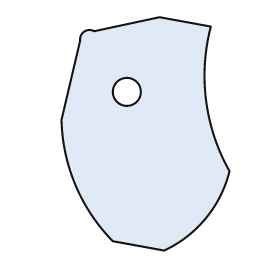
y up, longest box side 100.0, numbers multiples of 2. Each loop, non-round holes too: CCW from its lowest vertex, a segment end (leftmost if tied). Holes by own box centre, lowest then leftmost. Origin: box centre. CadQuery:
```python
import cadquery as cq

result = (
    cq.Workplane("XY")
    .moveTo(8.0, -50.0)
    .threePointArc((26.0, -36.0), (36.0, -16.0))
    .threePointArc((26.0, 14.0), (28.0, 46.0))
    .lineTo(6.0, 50.0)
    .lineTo(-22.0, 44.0)
    .threePointArc((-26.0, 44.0), (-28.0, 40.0))
    .lineTo(-36.0, 6.0)
    .threePointArc((-30.0, -22.0), (-14.0, -46.0))
    .close()
    .moveTo(-8.0, 18.0)
    .circle(6.0)
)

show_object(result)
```